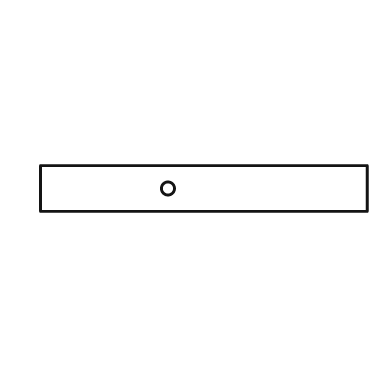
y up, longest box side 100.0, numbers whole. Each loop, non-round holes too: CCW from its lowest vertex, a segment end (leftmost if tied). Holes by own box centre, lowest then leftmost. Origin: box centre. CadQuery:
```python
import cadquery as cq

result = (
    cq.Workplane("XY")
    .moveTo(-50.0, -7.0)
    .lineTo(50.0, -7.0)
    .lineTo(50.0, 7.0)
    .lineTo(-50.0, 7.0)
    .close()
    .moveTo(-11.0, 0.0)
    .circle(2.0)
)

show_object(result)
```